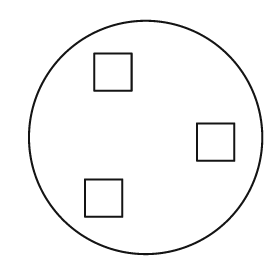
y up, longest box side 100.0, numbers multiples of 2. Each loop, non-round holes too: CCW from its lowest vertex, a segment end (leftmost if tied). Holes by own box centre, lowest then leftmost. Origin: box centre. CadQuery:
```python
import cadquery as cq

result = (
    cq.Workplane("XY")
    .moveTo(0.0, 0.0)
    .circle(50.0)
    .moveTo(-26.0, -34.0)
    .lineTo(-10.0, -34.0)
    .lineTo(-10.0, -18.0)
    .lineTo(-26.0, -18.0)
    .close()
    .moveTo(22.0, -10.0)
    .lineTo(38.0, -10.0)
    .lineTo(38.0, 6.0)
    .lineTo(22.0, 6.0)
    .close()
    .moveTo(-22.0, 20.0)
    .lineTo(-6.0, 20.0)
    .lineTo(-6.0, 36.0)
    .lineTo(-22.0, 36.0)
    .close()
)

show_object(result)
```